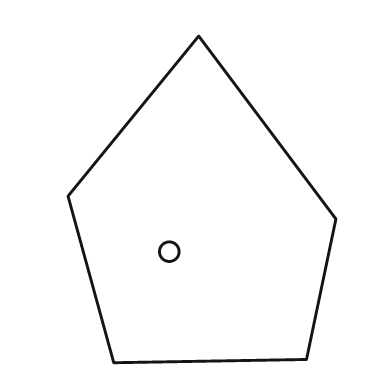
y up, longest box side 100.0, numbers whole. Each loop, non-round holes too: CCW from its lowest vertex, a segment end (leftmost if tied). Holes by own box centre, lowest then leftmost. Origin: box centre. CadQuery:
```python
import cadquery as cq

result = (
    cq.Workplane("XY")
    .moveTo(-27.0, -50.0)
    .lineTo(32.0, -49.0)
    .lineTo(41.0, -6.0)
    .lineTo(-1.0, 50.0)
    .lineTo(-41.0, 1.0)
    .close()
    .moveTo(-10.0, -16.0)
    .circle(3.0)
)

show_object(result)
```